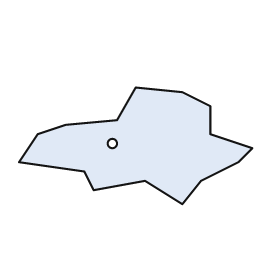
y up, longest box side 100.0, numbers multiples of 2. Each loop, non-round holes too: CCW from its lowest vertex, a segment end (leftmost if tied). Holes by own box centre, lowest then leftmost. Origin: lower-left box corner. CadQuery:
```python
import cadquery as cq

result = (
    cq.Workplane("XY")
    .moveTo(70.0, 0.0)
    .lineTo(78.0, 10.0)
    .lineTo(94.0, 18.0)
    .lineTo(100.0, 24.0)
    .lineTo(82.0, 30.0)
    .lineTo(82.0, 42.0)
    .lineTo(70.0, 48.0)
    .lineTo(50.0, 50.0)
    .lineTo(42.0, 36.0)
    .lineTo(20.0, 34.0)
    .lineTo(8.0, 30.0)
    .lineTo(0.0, 18.0)
    .lineTo(28.0, 14.0)
    .lineTo(32.0, 6.0)
    .lineTo(54.0, 10.0)
    .close()
    .moveTo(40.0, 26.0)
    .circle(2.0)
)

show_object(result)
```